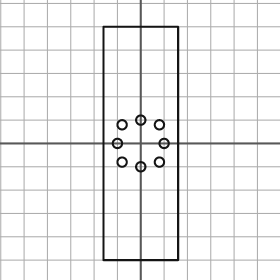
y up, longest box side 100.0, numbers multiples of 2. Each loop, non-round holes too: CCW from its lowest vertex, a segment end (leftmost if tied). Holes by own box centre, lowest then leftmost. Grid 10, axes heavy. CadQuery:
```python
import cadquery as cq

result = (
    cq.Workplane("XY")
    .moveTo(-16.0, -50.0)
    .lineTo(16.0, -50.0)
    .lineTo(16.0, 50.0)
    .lineTo(-16.0, 50.0)
    .close()
    .moveTo(0.0, -10.0)
    .circle(2.0)
    .moveTo(-8.0, -8.0)
    .circle(2.0)
    .moveTo(8.0, -8.0)
    .circle(2.0)
    .moveTo(-10.0, 0.0)
    .circle(2.0)
    .moveTo(10.0, 0.0)
    .circle(2.0)
    .moveTo(-8.0, 8.0)
    .circle(2.0)
    .moveTo(8.0, 8.0)
    .circle(2.0)
    .moveTo(0.0, 10.0)
    .circle(2.0)
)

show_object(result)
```